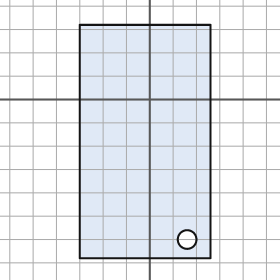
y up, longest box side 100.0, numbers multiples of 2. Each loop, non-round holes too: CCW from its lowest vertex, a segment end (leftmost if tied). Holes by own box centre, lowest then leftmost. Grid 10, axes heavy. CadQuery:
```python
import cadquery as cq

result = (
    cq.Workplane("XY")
    .moveTo(-30.0, -68.0)
    .lineTo(26.0, -68.0)
    .lineTo(26.0, 32.0)
    .lineTo(-30.0, 32.0)
    .close()
    .moveTo(16.0, -60.0)
    .circle(4.0)
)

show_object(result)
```